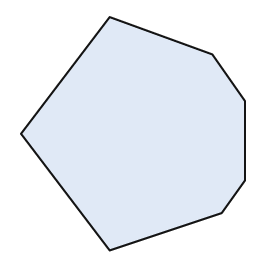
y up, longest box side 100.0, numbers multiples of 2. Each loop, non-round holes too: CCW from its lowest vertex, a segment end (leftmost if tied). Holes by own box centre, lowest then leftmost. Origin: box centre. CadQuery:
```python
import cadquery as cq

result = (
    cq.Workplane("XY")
    .moveTo(-10.0, -50.0)
    .lineTo(38.0, -34.0)
    .lineTo(48.0, -20.0)
    .lineTo(48.0, 14.0)
    .lineTo(34.0, 34.0)
    .lineTo(-10.0, 50.0)
    .lineTo(-48.0, 0.0)
    .close()
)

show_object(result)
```